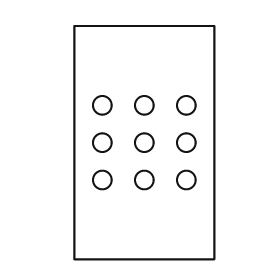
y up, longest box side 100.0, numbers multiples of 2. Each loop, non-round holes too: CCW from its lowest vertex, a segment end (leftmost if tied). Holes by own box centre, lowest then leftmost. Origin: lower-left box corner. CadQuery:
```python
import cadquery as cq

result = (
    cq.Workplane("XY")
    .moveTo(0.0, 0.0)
    .lineTo(60.0, 0.0)
    .lineTo(60.0, 100.0)
    .lineTo(0.0, 100.0)
    .close()
    .moveTo(12.0, 34.0)
    .circle(4.0)
    .moveTo(30.0, 34.0)
    .circle(4.0)
    .moveTo(48.0, 34.0)
    .circle(4.0)
    .moveTo(12.0, 50.0)
    .circle(4.0)
    .moveTo(30.0, 50.0)
    .circle(4.0)
    .moveTo(48.0, 50.0)
    .circle(4.0)
    .moveTo(12.0, 66.0)
    .circle(4.0)
    .moveTo(30.0, 66.0)
    .circle(4.0)
    .moveTo(48.0, 66.0)
    .circle(4.0)
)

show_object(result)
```